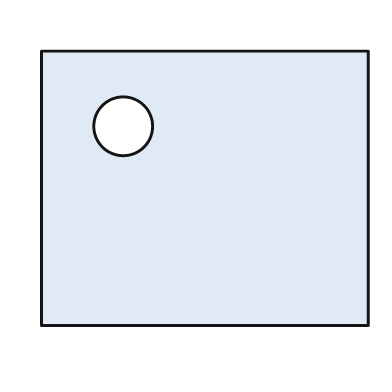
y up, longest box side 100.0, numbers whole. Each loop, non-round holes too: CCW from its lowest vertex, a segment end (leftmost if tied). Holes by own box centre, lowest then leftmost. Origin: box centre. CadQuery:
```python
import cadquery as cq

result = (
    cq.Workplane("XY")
    .moveTo(-50.0, -42.0)
    .lineTo(50.0, -42.0)
    .lineTo(50.0, 42.0)
    .lineTo(-50.0, 42.0)
    .close()
    .moveTo(-25.0, 19.0)
    .circle(9.0)
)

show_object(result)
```